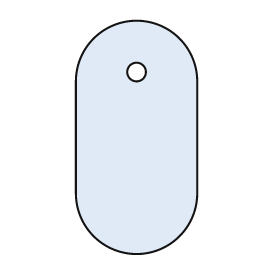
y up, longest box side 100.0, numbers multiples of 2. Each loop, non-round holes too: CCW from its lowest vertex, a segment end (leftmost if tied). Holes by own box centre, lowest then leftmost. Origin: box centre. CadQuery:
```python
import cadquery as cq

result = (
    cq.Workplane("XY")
    .moveTo(-26.0, -24.0)
    .threePointArc((0.0, -50.0), (26.0, -24.0))
    .lineTo(26.0, 24.0)
    .threePointArc((0.0, 50.0), (-26.0, 24.0))
    .close()
    .moveTo(0.0, 28.0)
    .circle(4.0)
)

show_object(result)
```